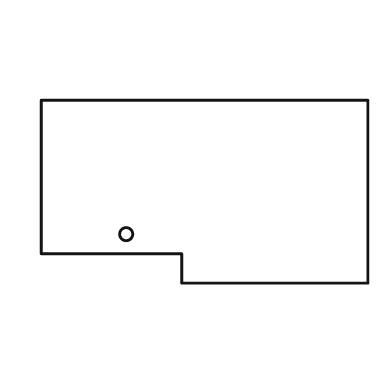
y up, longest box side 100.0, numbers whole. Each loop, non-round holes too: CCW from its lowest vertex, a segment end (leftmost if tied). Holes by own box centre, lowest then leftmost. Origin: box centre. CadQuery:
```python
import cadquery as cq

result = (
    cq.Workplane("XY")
    .moveTo(-7.0, -28.0)
    .lineTo(50.0, -28.0)
    .lineTo(50.0, 28.0)
    .lineTo(-50.0, 28.0)
    .lineTo(-50.0, -19.0)
    .lineTo(-7.0, -19.0)
    .close()
    .moveTo(-24.0, -13.0)
    .circle(2.0)
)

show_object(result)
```